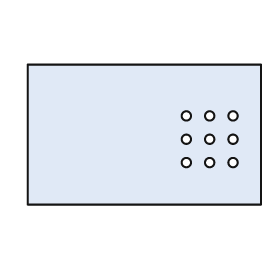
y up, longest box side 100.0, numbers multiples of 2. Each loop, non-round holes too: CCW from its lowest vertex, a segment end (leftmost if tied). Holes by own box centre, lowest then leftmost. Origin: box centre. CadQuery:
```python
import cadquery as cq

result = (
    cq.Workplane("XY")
    .moveTo(-50.0, -30.0)
    .lineTo(50.0, -30.0)
    .lineTo(50.0, 30.0)
    .lineTo(-50.0, 30.0)
    .close()
    .moveTo(18.0, -12.0)
    .circle(2.0)
    .moveTo(28.0, -12.0)
    .circle(2.0)
    .moveTo(38.0, -12.0)
    .circle(2.0)
    .moveTo(18.0, -2.0)
    .circle(2.0)
    .moveTo(28.0, -2.0)
    .circle(2.0)
    .moveTo(38.0, -2.0)
    .circle(2.0)
    .moveTo(18.0, 8.0)
    .circle(2.0)
    .moveTo(28.0, 8.0)
    .circle(2.0)
    .moveTo(38.0, 8.0)
    .circle(2.0)
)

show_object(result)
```